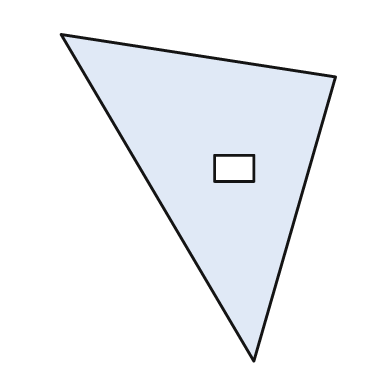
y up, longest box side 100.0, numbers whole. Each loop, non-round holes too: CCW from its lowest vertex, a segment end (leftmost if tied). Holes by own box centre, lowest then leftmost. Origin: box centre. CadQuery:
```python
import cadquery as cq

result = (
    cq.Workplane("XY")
    .moveTo(17.0, -50.0)
    .lineTo(42.0, 37.0)
    .lineTo(-42.0, 50.0)
    .close()
    .moveTo(5.0, 5.0)
    .lineTo(17.0, 5.0)
    .lineTo(17.0, 13.0)
    .lineTo(5.0, 13.0)
    .close()
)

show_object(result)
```